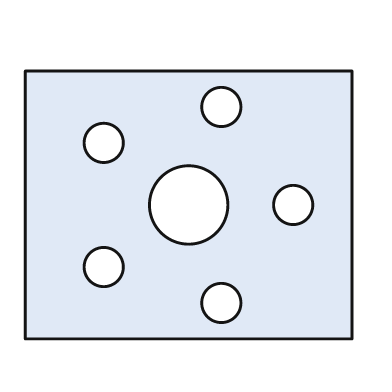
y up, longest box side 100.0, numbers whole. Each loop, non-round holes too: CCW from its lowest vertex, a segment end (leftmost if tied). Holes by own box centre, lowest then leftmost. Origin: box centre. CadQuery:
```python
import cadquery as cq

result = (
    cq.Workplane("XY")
    .moveTo(-50.0, -41.0)
    .lineTo(50.0, -41.0)
    .lineTo(50.0, 41.0)
    .lineTo(-50.0, 41.0)
    .close()
    .moveTo(10.0, -30.0)
    .circle(6.0)
    .moveTo(-26.0, -19.0)
    .circle(6.0)
    .moveTo(0.0, 0.0)
    .circle(12.0)
    .moveTo(32.0, 0.0)
    .circle(6.0)
    .moveTo(-26.0, 19.0)
    .circle(6.0)
    .moveTo(10.0, 30.0)
    .circle(6.0)
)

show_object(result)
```